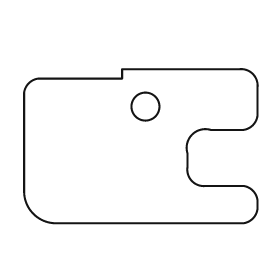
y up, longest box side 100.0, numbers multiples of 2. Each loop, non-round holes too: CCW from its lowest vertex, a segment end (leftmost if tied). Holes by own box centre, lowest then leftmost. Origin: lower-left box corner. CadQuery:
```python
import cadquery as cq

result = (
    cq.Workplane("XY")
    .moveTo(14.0, 0.0)
    .lineTo(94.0, 0.0)
    .threePointArc((98.0, 2.0), (100.0, 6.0))
    .lineTo(100.0, 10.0)
    .threePointArc((98.0, 14.0), (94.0, 16.0))
    .lineTo(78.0, 16.0)
    .threePointArc((72.0, 18.0), (70.0, 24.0))
    .lineTo(70.0, 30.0)
    .threePointArc((72.0, 38.0), (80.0, 40.0))
    .lineTo(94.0, 40.0)
    .threePointArc((98.0, 42.0), (100.0, 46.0))
    .lineTo(100.0, 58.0)
    .threePointArc((98.0, 64.0), (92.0, 66.0))
    .lineTo(42.0, 66.0)
    .lineTo(42.0, 62.0)
    .lineTo(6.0, 62.0)
    .threePointArc((2.0, 60.0), (0.0, 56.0))
    .lineTo(0.0, 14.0)
    .threePointArc((4.0, 4.0), (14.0, 0.0))
    .close()
    .moveTo(52.0, 50.0)
    .circle(6.0)
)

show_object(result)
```